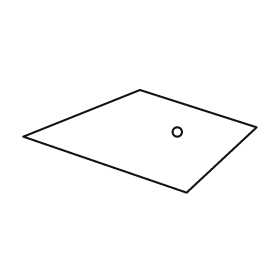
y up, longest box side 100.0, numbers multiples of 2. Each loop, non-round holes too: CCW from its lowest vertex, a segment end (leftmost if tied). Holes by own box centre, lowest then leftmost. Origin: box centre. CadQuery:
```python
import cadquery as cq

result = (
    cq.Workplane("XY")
    .moveTo(20.0, -22.0)
    .lineTo(50.0, 6.0)
    .lineTo(0.0, 22.0)
    .lineTo(-50.0, 2.0)
    .close()
    .moveTo(16.0, 4.0)
    .circle(2.0)
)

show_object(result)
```